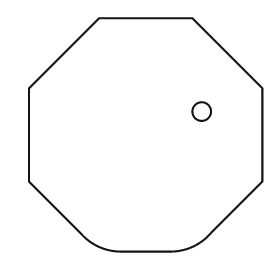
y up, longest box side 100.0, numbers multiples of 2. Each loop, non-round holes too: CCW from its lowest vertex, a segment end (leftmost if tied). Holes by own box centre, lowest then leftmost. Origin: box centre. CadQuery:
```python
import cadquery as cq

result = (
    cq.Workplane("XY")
    .moveTo(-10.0, -50.0)
    .lineTo(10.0, -50.0)
    .threePointArc((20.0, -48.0), (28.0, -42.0))
    .lineTo(50.0, -20.0)
    .lineTo(50.0, 20.0)
    .lineTo(20.0, 50.0)
    .lineTo(-20.0, 50.0)
    .lineTo(-50.0, 20.0)
    .lineTo(-50.0, -20.0)
    .lineTo(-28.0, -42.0)
    .threePointArc((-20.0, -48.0), (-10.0, -50.0))
    .close()
    .moveTo(24.0, 10.0)
    .circle(4.0)
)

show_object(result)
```